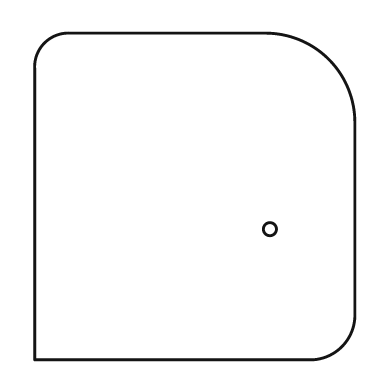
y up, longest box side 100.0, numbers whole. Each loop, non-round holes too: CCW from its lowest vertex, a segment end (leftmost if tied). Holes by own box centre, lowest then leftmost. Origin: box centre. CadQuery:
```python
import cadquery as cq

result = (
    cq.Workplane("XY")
    .moveTo(-49.0, -50.0)
    .lineTo(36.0, -50.0)
    .threePointArc((45.0, -46.0), (49.0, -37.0))
    .lineTo(49.0, 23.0)
    .threePointArc((41.0, 42.0), (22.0, 50.0))
    .lineTo(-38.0, 50.0)
    .threePointArc((-46.0, 47.0), (-49.0, 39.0))
    .close()
    .moveTo(23.0, -10.0)
    .circle(2.0)
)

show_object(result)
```